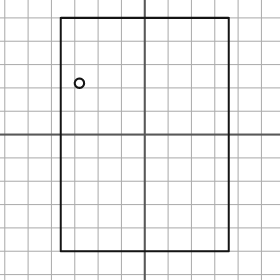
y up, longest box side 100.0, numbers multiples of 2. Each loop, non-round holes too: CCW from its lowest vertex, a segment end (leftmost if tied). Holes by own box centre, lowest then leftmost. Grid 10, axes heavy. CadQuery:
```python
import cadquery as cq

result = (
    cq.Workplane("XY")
    .moveTo(-36.0, -50.0)
    .lineTo(36.0, -50.0)
    .lineTo(36.0, 50.0)
    .lineTo(-36.0, 50.0)
    .close()
    .moveTo(-28.0, 22.0)
    .circle(2.0)
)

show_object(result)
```